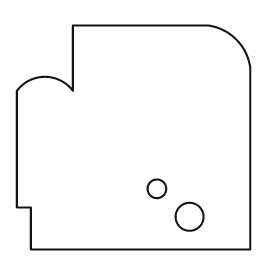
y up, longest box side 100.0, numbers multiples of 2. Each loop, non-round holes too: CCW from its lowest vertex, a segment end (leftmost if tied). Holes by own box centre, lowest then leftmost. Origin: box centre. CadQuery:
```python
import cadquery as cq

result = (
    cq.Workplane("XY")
    .moveTo(-44.0, -48.0)
    .lineTo(50.0, -48.0)
    .lineTo(50.0, 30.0)
    .threePointArc((44.0, 42.0), (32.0, 48.0))
    .lineTo(-26.0, 48.0)
    .lineTo(-26.0, 20.0)
    .threePointArc((-38.0, 26.0), (-50.0, 20.0))
    .lineTo(-50.0, -30.0)
    .lineTo(-44.0, -30.0)
    .close()
    .moveTo(24.0, -34.0)
    .circle(6.0)
    .moveTo(10.0, -22.0)
    .circle(4.0)
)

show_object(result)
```